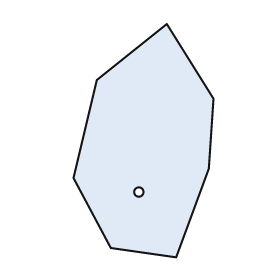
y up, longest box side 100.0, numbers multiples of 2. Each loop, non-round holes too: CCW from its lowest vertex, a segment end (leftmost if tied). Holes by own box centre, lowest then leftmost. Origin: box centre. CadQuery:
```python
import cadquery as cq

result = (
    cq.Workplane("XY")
    .moveTo(14.0, -50.0)
    .lineTo(28.0, -12.0)
    .lineTo(30.0, 18.0)
    .lineTo(10.0, 50.0)
    .lineTo(-20.0, 26.0)
    .lineTo(-30.0, -16.0)
    .lineTo(-14.0, -46.0)
    .close()
    .moveTo(-2.0, -22.0)
    .circle(2.0)
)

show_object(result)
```